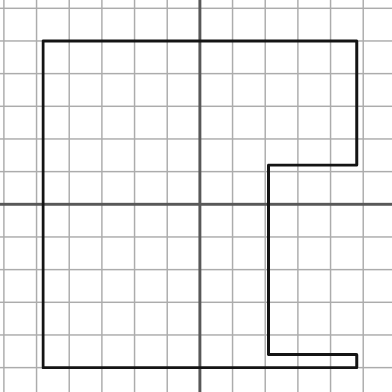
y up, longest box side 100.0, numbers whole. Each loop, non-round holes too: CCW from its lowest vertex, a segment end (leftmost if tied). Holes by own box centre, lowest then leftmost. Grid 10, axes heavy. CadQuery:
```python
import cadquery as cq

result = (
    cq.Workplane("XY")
    .moveTo(-48.0, -50.0)
    .lineTo(48.0, -50.0)
    .lineTo(48.0, -46.0)
    .lineTo(21.0, -46.0)
    .lineTo(21.0, 12.0)
    .lineTo(48.0, 12.0)
    .lineTo(48.0, 50.0)
    .lineTo(-48.0, 50.0)
    .close()
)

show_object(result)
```